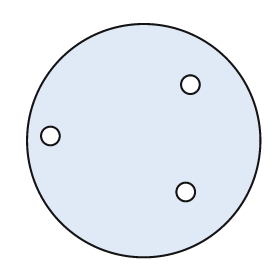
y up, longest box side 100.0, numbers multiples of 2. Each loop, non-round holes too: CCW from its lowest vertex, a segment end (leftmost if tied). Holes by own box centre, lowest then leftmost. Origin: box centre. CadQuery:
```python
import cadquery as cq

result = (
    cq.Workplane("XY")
    .moveTo(0.0, 0.0)
    .circle(50.0)
    .moveTo(18.0, -22.0)
    .circle(4.0)
    .moveTo(-40.0, 2.0)
    .circle(4.0)
    .moveTo(20.0, 24.0)
    .circle(4.0)
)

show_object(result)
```